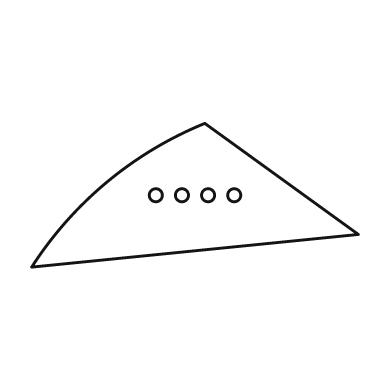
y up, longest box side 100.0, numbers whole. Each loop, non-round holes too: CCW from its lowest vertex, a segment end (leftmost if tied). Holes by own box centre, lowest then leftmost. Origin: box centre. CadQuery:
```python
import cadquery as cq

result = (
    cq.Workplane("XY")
    .moveTo(-50.0, -22.0)
    .lineTo(50.0, -12.0)
    .lineTo(3.0, 22.0)
    .threePointArc((-27.0, 4.0), (-50.0, -22.0))
    .close()
    .moveTo(-12.0, 0.0)
    .circle(2.0)
    .moveTo(-4.0, 0.0)
    .circle(2.0)
    .moveTo(4.0, 0.0)
    .circle(2.0)
    .moveTo(12.0, 0.0)
    .circle(2.0)
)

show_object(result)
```